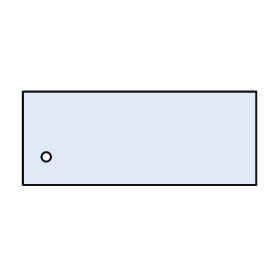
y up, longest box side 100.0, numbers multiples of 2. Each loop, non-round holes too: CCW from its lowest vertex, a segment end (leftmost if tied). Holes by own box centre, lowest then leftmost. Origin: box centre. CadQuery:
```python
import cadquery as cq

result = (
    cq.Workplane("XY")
    .moveTo(-50.0, -20.0)
    .lineTo(50.0, -20.0)
    .lineTo(50.0, 20.0)
    .lineTo(-50.0, 20.0)
    .close()
    .moveTo(-40.0, -8.0)
    .circle(2.0)
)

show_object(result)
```